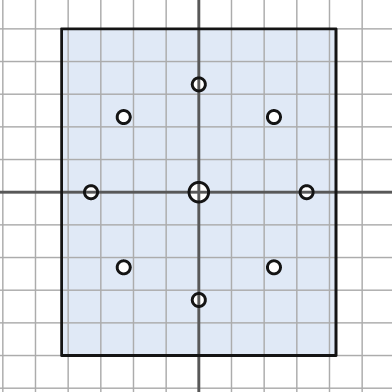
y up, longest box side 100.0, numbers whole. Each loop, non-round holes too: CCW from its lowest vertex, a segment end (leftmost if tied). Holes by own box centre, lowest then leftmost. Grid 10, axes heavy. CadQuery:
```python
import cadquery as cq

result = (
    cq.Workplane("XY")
    .moveTo(-42.0, -50.0)
    .lineTo(42.0, -50.0)
    .lineTo(42.0, 50.0)
    .lineTo(-42.0, 50.0)
    .close()
    .moveTo(0.0, -33.0)
    .circle(2.0)
    .moveTo(-23.0, -23.0)
    .circle(2.0)
    .moveTo(23.0, -23.0)
    .circle(2.0)
    .moveTo(-33.0, 0.0)
    .circle(2.0)
    .moveTo(0.0, 0.0)
    .circle(3.0)
    .moveTo(33.0, 0.0)
    .circle(2.0)
    .moveTo(-23.0, 23.0)
    .circle(2.0)
    .moveTo(23.0, 23.0)
    .circle(2.0)
    .moveTo(0.0, 33.0)
    .circle(2.0)
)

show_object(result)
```